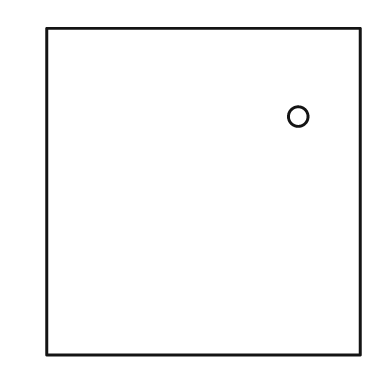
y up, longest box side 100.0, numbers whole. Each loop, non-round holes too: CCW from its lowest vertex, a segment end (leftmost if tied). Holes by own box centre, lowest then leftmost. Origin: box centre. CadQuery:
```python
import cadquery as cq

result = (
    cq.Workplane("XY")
    .moveTo(-48.0, -50.0)
    .lineTo(48.0, -50.0)
    .lineTo(48.0, 50.0)
    .lineTo(-48.0, 50.0)
    .close()
    .moveTo(29.0, 23.0)
    .circle(3.0)
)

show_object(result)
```